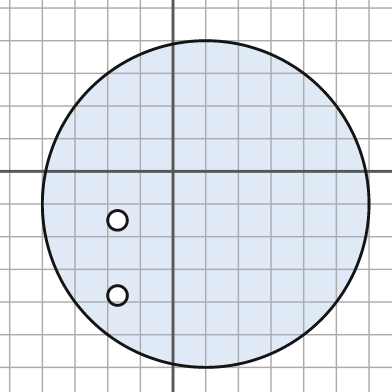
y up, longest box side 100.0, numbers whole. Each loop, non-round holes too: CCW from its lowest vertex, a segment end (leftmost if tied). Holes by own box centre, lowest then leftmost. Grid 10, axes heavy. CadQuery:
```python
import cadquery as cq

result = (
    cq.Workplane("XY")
    .moveTo(10.0, -10.0)
    .circle(50.0)
    .moveTo(-17.0, -38.0)
    .circle(3.0)
    .moveTo(-17.0, -15.0)
    .circle(3.0)
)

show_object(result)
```